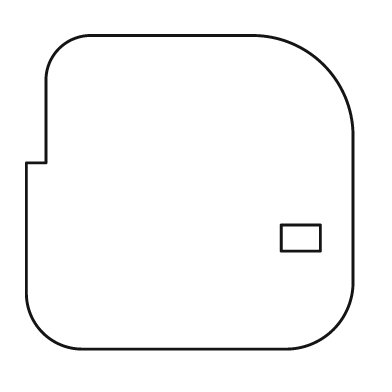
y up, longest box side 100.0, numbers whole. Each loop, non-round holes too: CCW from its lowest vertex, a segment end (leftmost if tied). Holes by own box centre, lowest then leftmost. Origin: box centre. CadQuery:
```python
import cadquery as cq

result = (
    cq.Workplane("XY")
    .moveTo(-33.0, -48.0)
    .lineTo(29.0, -48.0)
    .threePointArc((44.0, -42.0), (50.0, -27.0))
    .lineTo(50.0, 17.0)
    .threePointArc((41.0, 39.0), (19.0, 48.0))
    .lineTo(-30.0, 48.0)
    .threePointArc((-40.0, 44.0), (-44.0, 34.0))
    .lineTo(-44.0, 9.0)
    .lineTo(-50.0, 9.0)
    .lineTo(-50.0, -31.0)
    .threePointArc((-45.0, -43.0), (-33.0, -48.0))
    .close()
    .moveTo(28.0, -18.0)
    .lineTo(40.0, -18.0)
    .lineTo(40.0, -10.0)
    .lineTo(28.0, -10.0)
    .close()
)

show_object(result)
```